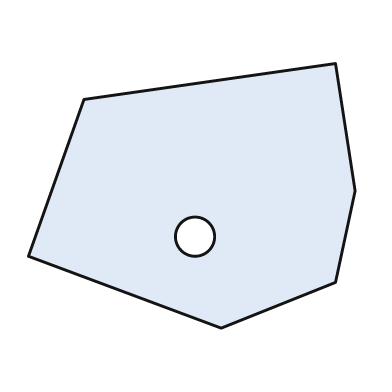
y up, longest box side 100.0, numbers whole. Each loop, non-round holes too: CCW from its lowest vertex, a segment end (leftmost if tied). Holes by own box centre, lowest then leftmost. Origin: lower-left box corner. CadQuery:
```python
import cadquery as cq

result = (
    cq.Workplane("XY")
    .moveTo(59.0, 0.0)
    .lineTo(94.0, 14.0)
    .lineTo(100.0, 42.0)
    .lineTo(94.0, 81.0)
    .lineTo(17.0, 70.0)
    .lineTo(0.0, 22.0)
    .close()
    .moveTo(51.0, 28.0)
    .circle(6.0)
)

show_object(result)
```